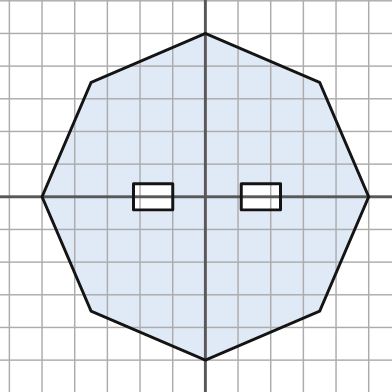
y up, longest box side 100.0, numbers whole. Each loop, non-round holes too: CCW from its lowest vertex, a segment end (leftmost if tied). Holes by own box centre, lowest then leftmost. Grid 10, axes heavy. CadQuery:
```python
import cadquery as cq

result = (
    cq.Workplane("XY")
    .moveTo(0.0, -50.0)
    .lineTo(35.0, -35.0)
    .lineTo(50.0, 0.0)
    .lineTo(35.0, 35.0)
    .lineTo(0.0, 50.0)
    .lineTo(-35.0, 35.0)
    .lineTo(-50.0, 0.0)
    .lineTo(-35.0, -35.0)
    .close()
    .moveTo(-22.0, -4.0)
    .lineTo(-10.0, -4.0)
    .lineTo(-10.0, 4.0)
    .lineTo(-22.0, 4.0)
    .close()
    .moveTo(11.0, -4.0)
    .lineTo(23.0, -4.0)
    .lineTo(23.0, 4.0)
    .lineTo(11.0, 4.0)
    .close()
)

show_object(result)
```